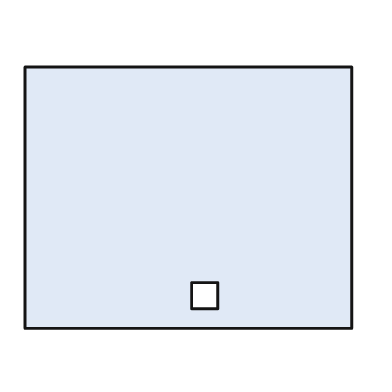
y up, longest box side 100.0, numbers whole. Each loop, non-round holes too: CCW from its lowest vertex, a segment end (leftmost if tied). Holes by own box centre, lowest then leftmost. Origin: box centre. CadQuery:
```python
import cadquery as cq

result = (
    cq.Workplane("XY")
    .moveTo(-50.0, -40.0)
    .lineTo(50.0, -40.0)
    .lineTo(50.0, 40.0)
    .lineTo(-50.0, 40.0)
    .close()
    .moveTo(1.0, -34.0)
    .lineTo(9.0, -34.0)
    .lineTo(9.0, -26.0)
    .lineTo(1.0, -26.0)
    .close()
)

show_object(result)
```